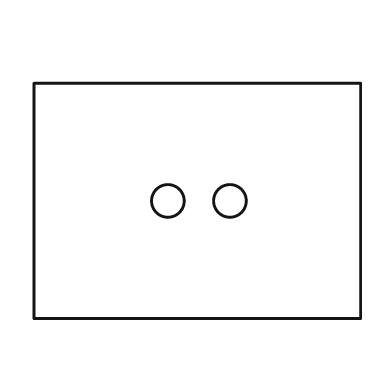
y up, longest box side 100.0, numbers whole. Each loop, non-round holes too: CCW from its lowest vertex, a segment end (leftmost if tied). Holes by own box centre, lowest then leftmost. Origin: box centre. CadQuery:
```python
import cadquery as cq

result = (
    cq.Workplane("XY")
    .moveTo(-50.0, -36.0)
    .lineTo(50.0, -36.0)
    .lineTo(50.0, 36.0)
    .lineTo(-50.0, 36.0)
    .close()
    .moveTo(-9.0, 0.0)
    .circle(5.0)
    .moveTo(10.0, 0.0)
    .circle(5.0)
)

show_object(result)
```